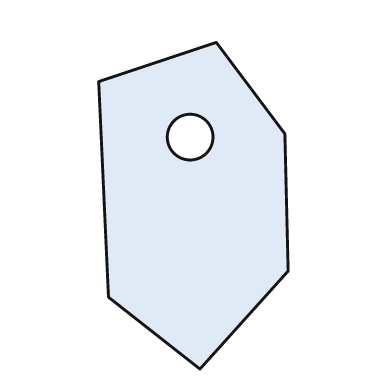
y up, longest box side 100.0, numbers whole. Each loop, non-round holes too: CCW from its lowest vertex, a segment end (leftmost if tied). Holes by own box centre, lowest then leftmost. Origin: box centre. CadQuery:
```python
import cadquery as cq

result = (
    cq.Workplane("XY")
    .moveTo(2.0, -50.0)
    .lineTo(29.0, -20.0)
    .lineTo(28.0, 22.0)
    .lineTo(7.0, 50.0)
    .lineTo(-29.0, 38.0)
    .lineTo(-26.0, -28.0)
    .close()
    .moveTo(-1.0, 21.0)
    .circle(7.0)
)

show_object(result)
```